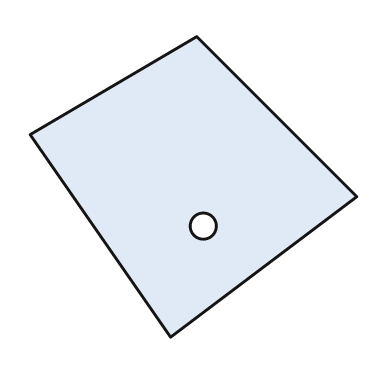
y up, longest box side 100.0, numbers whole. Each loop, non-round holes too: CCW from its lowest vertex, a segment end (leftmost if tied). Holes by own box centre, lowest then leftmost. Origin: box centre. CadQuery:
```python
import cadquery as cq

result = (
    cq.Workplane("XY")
    .moveTo(-7.0, -46.0)
    .lineTo(50.0, -3.0)
    .lineTo(1.0, 46.0)
    .lineTo(-50.0, 16.0)
    .close()
    .moveTo(3.0, -12.0)
    .circle(4.0)
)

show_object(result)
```